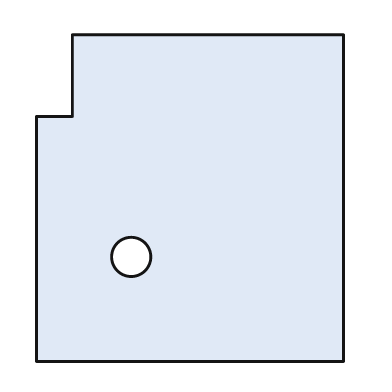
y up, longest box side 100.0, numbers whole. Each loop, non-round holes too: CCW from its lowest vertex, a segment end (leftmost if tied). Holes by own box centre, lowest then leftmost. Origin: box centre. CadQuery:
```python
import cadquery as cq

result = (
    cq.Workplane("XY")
    .moveTo(-47.0, -50.0)
    .lineTo(47.0, -50.0)
    .lineTo(47.0, 50.0)
    .lineTo(-36.0, 50.0)
    .lineTo(-36.0, 25.0)
    .lineTo(-47.0, 25.0)
    .close()
    .moveTo(-18.0, -18.0)
    .circle(6.0)
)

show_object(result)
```